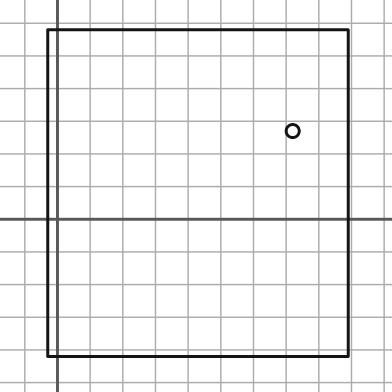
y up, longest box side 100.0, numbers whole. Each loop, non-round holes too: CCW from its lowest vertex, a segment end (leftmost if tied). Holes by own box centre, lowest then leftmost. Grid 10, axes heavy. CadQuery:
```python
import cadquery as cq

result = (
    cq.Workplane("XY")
    .moveTo(-3.0, -42.0)
    .lineTo(89.0, -42.0)
    .lineTo(89.0, 58.0)
    .lineTo(-3.0, 58.0)
    .close()
    .moveTo(72.0, 27.0)
    .circle(2.0)
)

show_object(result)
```